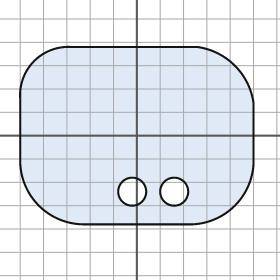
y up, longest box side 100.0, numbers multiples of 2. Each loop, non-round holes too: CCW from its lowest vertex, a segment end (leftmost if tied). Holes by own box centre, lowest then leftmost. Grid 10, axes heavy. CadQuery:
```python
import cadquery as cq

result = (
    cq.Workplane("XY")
    .moveTo(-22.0, -38.0)
    .lineTo(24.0, -38.0)
    .threePointArc((42.0, -30.0), (50.0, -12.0))
    .lineTo(50.0, 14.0)
    .threePointArc((42.0, 30.0), (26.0, 38.0))
    .lineTo(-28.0, 38.0)
    .threePointArc((-44.0, 32.0), (-50.0, 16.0))
    .lineTo(-50.0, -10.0)
    .threePointArc((-42.0, -30.0), (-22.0, -38.0))
    .close()
    .moveTo(-2.0, -24.0)
    .circle(6.0)
    .moveTo(16.0, -24.0)
    .circle(6.0)
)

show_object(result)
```